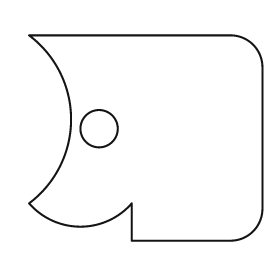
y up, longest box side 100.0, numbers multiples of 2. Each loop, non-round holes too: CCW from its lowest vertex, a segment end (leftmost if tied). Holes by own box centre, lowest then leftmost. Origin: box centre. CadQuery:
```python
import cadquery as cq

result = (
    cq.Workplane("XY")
    .moveTo(-6.0, -44.0)
    .lineTo(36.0, -44.0)
    .threePointArc((46.0, -40.0), (50.0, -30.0))
    .lineTo(50.0, 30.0)
    .threePointArc((46.0, 40.0), (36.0, 44.0))
    .lineTo(-50.0, 44.0)
    .threePointArc((-32.0, 8.0), (-50.0, -28.0))
    .threePointArc((-28.0, -38.0), (-6.0, -28.0))
    .close()
    .moveTo(-20.0, 4.0)
    .circle(8.0)
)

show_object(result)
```